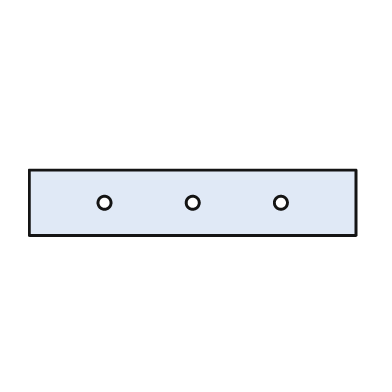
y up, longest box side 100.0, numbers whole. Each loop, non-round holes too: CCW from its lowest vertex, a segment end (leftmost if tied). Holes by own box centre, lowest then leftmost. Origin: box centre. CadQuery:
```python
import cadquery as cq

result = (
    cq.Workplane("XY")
    .moveTo(-50.0, -10.0)
    .lineTo(50.0, -10.0)
    .lineTo(50.0, 10.0)
    .lineTo(-50.0, 10.0)
    .close()
    .moveTo(-27.0, 0.0)
    .circle(2.0)
    .moveTo(0.0, 0.0)
    .circle(2.0)
    .moveTo(27.0, 0.0)
    .circle(2.0)
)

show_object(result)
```